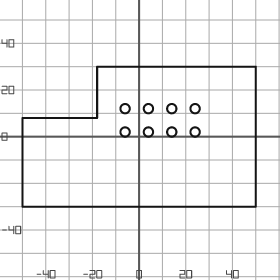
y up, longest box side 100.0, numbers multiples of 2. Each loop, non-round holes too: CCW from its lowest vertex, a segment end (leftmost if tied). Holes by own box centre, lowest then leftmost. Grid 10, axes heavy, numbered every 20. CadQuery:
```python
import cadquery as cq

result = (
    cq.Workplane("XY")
    .moveTo(-50.0, -30.0)
    .lineTo(50.0, -30.0)
    .lineTo(50.0, 30.0)
    .lineTo(-18.0, 30.0)
    .lineTo(-18.0, 8.0)
    .lineTo(-50.0, 8.0)
    .close()
    .moveTo(-6.0, 2.0)
    .circle(2.0)
    .moveTo(4.0, 2.0)
    .circle(2.0)
    .moveTo(14.0, 2.0)
    .circle(2.0)
    .moveTo(24.0, 2.0)
    .circle(2.0)
    .moveTo(-6.0, 12.0)
    .circle(2.0)
    .moveTo(4.0, 12.0)
    .circle(2.0)
    .moveTo(14.0, 12.0)
    .circle(2.0)
    .moveTo(24.0, 12.0)
    .circle(2.0)
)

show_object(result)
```